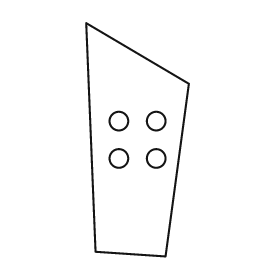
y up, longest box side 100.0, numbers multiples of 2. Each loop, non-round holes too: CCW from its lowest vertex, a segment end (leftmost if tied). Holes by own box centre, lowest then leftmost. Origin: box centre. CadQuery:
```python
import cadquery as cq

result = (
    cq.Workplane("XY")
    .moveTo(12.0, -50.0)
    .lineTo(22.0, 24.0)
    .lineTo(-22.0, 50.0)
    .lineTo(-18.0, -48.0)
    .close()
    .moveTo(-8.0, -8.0)
    .circle(4.0)
    .moveTo(8.0, -8.0)
    .circle(4.0)
    .moveTo(-8.0, 8.0)
    .circle(4.0)
    .moveTo(8.0, 8.0)
    .circle(4.0)
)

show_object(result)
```